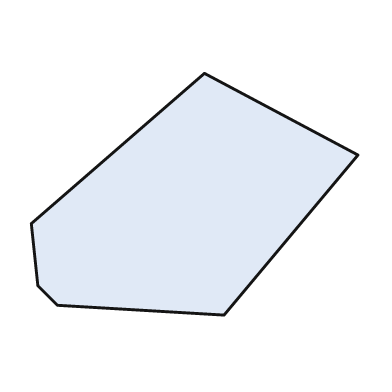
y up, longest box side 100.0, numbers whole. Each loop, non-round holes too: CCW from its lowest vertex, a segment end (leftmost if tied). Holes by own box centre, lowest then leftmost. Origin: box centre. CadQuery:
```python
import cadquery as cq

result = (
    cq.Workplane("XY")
    .moveTo(9.0, -37.0)
    .lineTo(50.0, 12.0)
    .lineTo(3.0, 37.0)
    .lineTo(-50.0, -9.0)
    .lineTo(-48.0, -28.0)
    .lineTo(-42.0, -34.0)
    .close()
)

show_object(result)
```